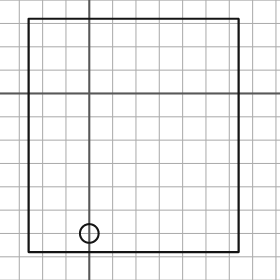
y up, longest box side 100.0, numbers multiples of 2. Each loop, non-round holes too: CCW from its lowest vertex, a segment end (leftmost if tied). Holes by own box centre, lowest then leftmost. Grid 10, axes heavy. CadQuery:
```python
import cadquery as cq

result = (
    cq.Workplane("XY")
    .moveTo(-26.0, -68.0)
    .lineTo(64.0, -68.0)
    .lineTo(64.0, 32.0)
    .lineTo(-26.0, 32.0)
    .close()
    .moveTo(0.0, -60.0)
    .circle(4.0)
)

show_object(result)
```